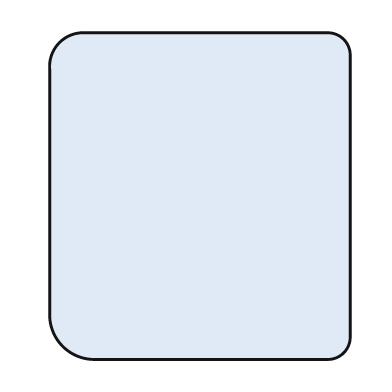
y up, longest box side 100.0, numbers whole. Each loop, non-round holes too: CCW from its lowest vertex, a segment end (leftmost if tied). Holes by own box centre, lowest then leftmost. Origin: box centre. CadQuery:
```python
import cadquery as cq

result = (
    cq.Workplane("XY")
    .moveTo(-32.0, -50.0)
    .lineTo(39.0, -50.0)
    .threePointArc((44.0, -48.0), (46.0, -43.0))
    .lineTo(46.0, 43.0)
    .threePointArc((44.0, 48.0), (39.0, 50.0))
    .lineTo(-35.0, 50.0)
    .threePointArc((-43.0, 47.0), (-46.0, 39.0))
    .lineTo(-46.0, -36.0)
    .threePointArc((-42.0, -46.0), (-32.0, -50.0))
    .close()
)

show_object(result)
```